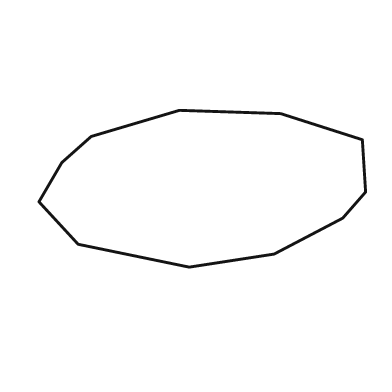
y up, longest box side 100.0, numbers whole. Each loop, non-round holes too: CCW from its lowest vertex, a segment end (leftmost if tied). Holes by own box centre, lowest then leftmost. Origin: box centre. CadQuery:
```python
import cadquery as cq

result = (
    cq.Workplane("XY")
    .moveTo(-4.0, -24.0)
    .lineTo(22.0, -20.0)
    .lineTo(43.0, -9.0)
    .lineTo(50.0, -1.0)
    .lineTo(49.0, 15.0)
    .lineTo(24.0, 23.0)
    .lineTo(-7.0, 24.0)
    .lineTo(-34.0, 16.0)
    .lineTo(-43.0, 8.0)
    .lineTo(-50.0, -4.0)
    .lineTo(-38.0, -17.0)
    .close()
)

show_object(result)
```